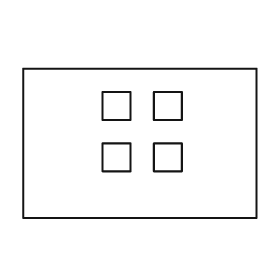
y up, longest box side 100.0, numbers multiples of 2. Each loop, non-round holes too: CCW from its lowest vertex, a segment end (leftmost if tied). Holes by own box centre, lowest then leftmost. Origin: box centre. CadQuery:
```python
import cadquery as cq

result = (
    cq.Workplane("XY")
    .moveTo(-50.0, -32.0)
    .lineTo(50.0, -32.0)
    .lineTo(50.0, 32.0)
    .lineTo(-50.0, 32.0)
    .close()
    .moveTo(-16.0, -12.0)
    .lineTo(-4.0, -12.0)
    .lineTo(-4.0, 0.0)
    .lineTo(-16.0, 0.0)
    .close()
    .moveTo(6.0, -12.0)
    .lineTo(18.0, -12.0)
    .lineTo(18.0, 0.0)
    .lineTo(6.0, 0.0)
    .close()
    .moveTo(-16.0, 10.0)
    .lineTo(-4.0, 10.0)
    .lineTo(-4.0, 22.0)
    .lineTo(-16.0, 22.0)
    .close()
    .moveTo(6.0, 10.0)
    .lineTo(18.0, 10.0)
    .lineTo(18.0, 22.0)
    .lineTo(6.0, 22.0)
    .close()
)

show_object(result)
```